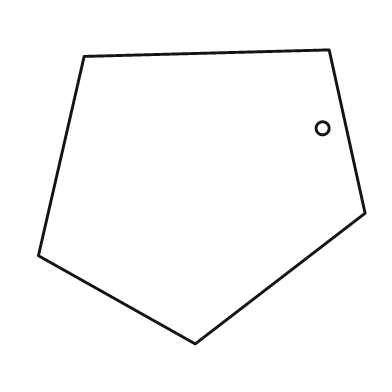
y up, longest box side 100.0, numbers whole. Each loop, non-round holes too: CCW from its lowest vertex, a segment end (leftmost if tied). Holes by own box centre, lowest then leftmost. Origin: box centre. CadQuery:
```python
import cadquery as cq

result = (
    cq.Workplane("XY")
    .moveTo(-2.0, -45.0)
    .lineTo(50.0, -5.0)
    .lineTo(39.0, 45.0)
    .lineTo(-36.0, 43.0)
    .lineTo(-50.0, -18.0)
    .close()
    .moveTo(37.0, 21.0)
    .circle(2.0)
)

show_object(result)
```